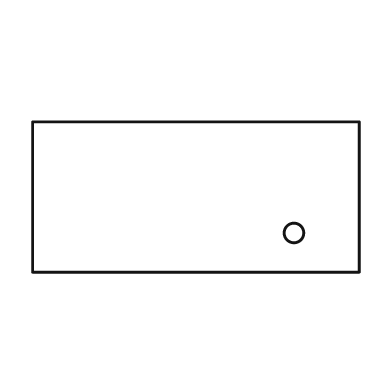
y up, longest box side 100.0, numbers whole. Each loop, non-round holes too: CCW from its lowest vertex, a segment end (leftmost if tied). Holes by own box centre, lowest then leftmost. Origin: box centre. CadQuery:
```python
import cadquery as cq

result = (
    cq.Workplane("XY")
    .moveTo(-50.0, -23.0)
    .lineTo(50.0, -23.0)
    .lineTo(50.0, 23.0)
    .lineTo(-50.0, 23.0)
    .close()
    .moveTo(30.0, -11.0)
    .circle(3.0)
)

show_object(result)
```